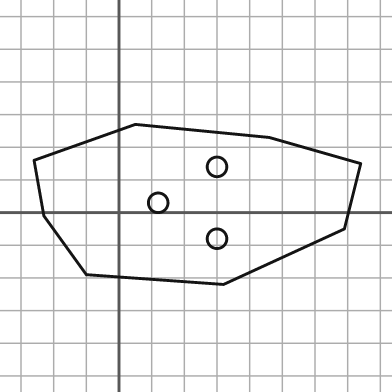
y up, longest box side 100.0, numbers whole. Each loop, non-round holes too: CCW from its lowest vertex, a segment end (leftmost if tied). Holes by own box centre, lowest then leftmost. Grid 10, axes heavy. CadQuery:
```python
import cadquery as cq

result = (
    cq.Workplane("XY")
    .moveTo(32.0, -22.0)
    .lineTo(69.0, -5.0)
    .lineTo(74.0, 15.0)
    .lineTo(46.0, 23.0)
    .lineTo(5.0, 27.0)
    .lineTo(-26.0, 16.0)
    .lineTo(-23.0, -1.0)
    .lineTo(-10.0, -19.0)
    .close()
    .moveTo(30.0, -8.0)
    .circle(3.0)
    .moveTo(12.0, 3.0)
    .circle(3.0)
    .moveTo(30.0, 14.0)
    .circle(3.0)
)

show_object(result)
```